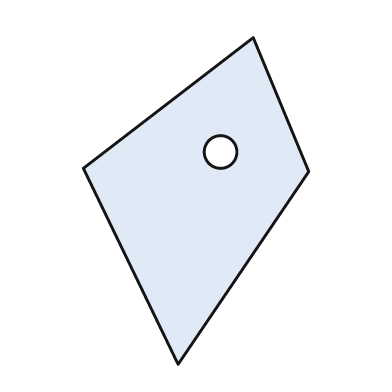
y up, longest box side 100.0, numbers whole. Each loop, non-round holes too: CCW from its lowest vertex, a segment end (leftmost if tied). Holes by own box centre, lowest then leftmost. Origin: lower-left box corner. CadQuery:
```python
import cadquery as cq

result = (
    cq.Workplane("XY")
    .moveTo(29.0, 0.0)
    .lineTo(69.0, 59.0)
    .lineTo(52.0, 100.0)
    .lineTo(0.0, 60.0)
    .close()
    .moveTo(42.0, 65.0)
    .circle(5.0)
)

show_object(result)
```